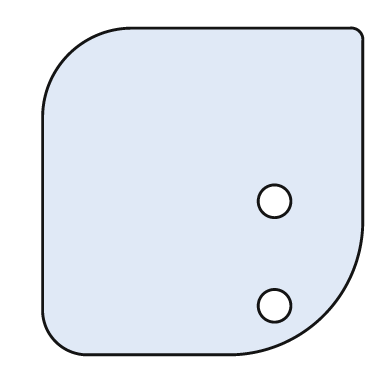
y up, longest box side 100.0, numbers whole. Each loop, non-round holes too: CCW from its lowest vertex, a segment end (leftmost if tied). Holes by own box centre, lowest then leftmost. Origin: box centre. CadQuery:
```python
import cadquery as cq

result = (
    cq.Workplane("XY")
    .moveTo(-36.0, -50.0)
    .lineTo(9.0, -50.0)
    .threePointArc((37.0, -38.0), (49.0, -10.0))
    .lineTo(49.0, 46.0)
    .threePointArc((48.0, 49.0), (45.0, 50.0))
    .lineTo(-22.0, 50.0)
    .threePointArc((-41.0, 42.0), (-49.0, 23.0))
    .lineTo(-49.0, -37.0)
    .threePointArc((-45.0, -46.0), (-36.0, -50.0))
    .close()
    .moveTo(22.0, -35.0)
    .circle(5.0)
    .moveTo(22.0, -3.0)
    .circle(5.0)
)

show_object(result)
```